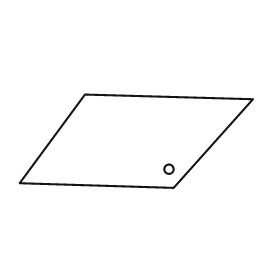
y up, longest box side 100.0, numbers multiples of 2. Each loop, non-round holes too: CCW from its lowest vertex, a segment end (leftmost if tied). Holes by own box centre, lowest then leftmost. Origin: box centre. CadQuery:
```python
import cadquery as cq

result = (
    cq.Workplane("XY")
    .moveTo(16.0, -20.0)
    .lineTo(50.0, 18.0)
    .lineTo(-22.0, 20.0)
    .lineTo(-50.0, -18.0)
    .close()
    .moveTo(14.0, -12.0)
    .circle(2.0)
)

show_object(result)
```